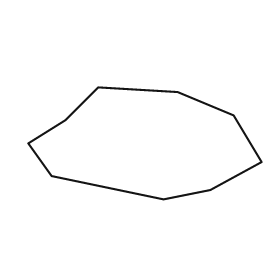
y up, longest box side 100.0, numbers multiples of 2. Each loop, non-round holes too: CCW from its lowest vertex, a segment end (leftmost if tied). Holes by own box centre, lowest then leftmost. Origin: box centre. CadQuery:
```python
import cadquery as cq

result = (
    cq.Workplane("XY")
    .moveTo(8.0, -24.0)
    .lineTo(28.0, -20.0)
    .lineTo(50.0, -8.0)
    .lineTo(38.0, 12.0)
    .lineTo(14.0, 22.0)
    .lineTo(-20.0, 24.0)
    .lineTo(-34.0, 10.0)
    .lineTo(-50.0, 0.0)
    .lineTo(-40.0, -14.0)
    .close()
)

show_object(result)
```